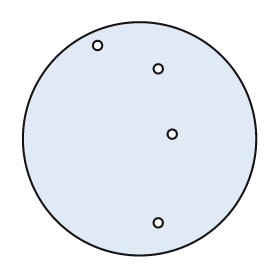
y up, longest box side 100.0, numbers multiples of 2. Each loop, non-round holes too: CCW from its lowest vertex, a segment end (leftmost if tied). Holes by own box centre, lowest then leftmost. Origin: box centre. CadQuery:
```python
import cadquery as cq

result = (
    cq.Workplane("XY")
    .moveTo(0.0, 0.0)
    .circle(50.0)
    .moveTo(8.0, -36.0)
    .circle(2.0)
    .moveTo(14.0, 2.0)
    .circle(2.0)
    .moveTo(8.0, 30.0)
    .circle(2.0)
    .moveTo(-18.0, 40.0)
    .circle(2.0)
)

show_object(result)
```